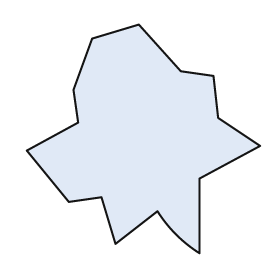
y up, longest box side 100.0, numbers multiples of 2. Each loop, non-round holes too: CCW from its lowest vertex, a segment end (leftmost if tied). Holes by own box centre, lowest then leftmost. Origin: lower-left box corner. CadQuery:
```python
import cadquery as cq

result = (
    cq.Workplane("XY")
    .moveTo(74.0, 0.0)
    .lineTo(74.0, 32.0)
    .lineTo(100.0, 46.0)
    .lineTo(82.0, 58.0)
    .lineTo(80.0, 76.0)
    .lineTo(66.0, 78.0)
    .lineTo(48.0, 98.0)
    .lineTo(28.0, 92.0)
    .lineTo(20.0, 70.0)
    .lineTo(22.0, 56.0)
    .lineTo(0.0, 44.0)
    .lineTo(18.0, 22.0)
    .lineTo(32.0, 24.0)
    .lineTo(38.0, 4.0)
    .lineTo(56.0, 18.0)
    .threePointArc((64.0, 8.0), (74.0, 0.0))
    .close()
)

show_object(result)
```